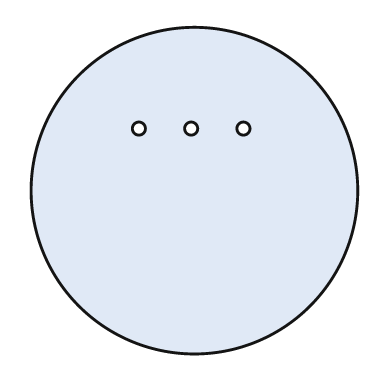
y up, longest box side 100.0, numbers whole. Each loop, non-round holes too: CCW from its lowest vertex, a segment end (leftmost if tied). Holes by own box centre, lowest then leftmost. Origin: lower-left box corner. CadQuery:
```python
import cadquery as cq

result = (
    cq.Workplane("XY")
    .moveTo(50.0, 50.0)
    .circle(50.0)
    .moveTo(33.0, 69.0)
    .circle(2.0)
    .moveTo(49.0, 69.0)
    .circle(2.0)
    .moveTo(65.0, 69.0)
    .circle(2.0)
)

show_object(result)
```